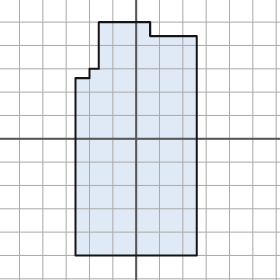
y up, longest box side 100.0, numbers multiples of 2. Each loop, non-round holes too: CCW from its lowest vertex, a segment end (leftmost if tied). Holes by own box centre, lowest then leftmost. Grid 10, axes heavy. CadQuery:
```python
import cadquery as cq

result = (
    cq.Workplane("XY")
    .moveTo(-26.0, -50.0)
    .lineTo(26.0, -50.0)
    .lineTo(26.0, 44.0)
    .lineTo(6.0, 44.0)
    .lineTo(6.0, 50.0)
    .lineTo(-16.0, 50.0)
    .lineTo(-16.0, 30.0)
    .lineTo(-20.0, 30.0)
    .lineTo(-20.0, 26.0)
    .lineTo(-26.0, 26.0)
    .close()
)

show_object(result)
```